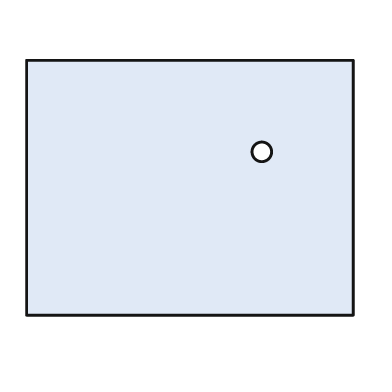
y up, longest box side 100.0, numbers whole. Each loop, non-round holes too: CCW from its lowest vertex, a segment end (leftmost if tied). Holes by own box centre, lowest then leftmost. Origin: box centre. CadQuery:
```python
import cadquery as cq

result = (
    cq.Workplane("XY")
    .moveTo(-50.0, -39.0)
    .lineTo(50.0, -39.0)
    .lineTo(50.0, 39.0)
    .lineTo(-50.0, 39.0)
    .close()
    .moveTo(22.0, 11.0)
    .circle(3.0)
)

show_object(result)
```